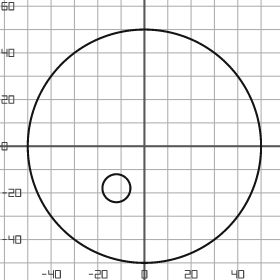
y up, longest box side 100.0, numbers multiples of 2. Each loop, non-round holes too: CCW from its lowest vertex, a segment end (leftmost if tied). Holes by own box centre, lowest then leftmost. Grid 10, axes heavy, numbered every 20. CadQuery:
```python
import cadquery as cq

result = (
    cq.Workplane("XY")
    .moveTo(0.0, 0.0)
    .circle(50.0)
    .moveTo(-12.0, -18.0)
    .circle(6.0)
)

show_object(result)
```